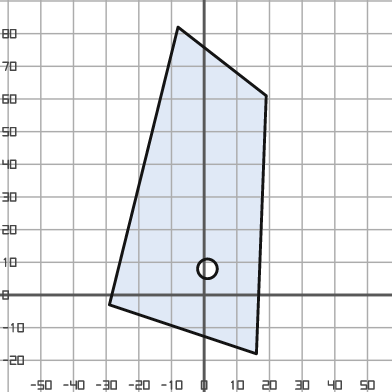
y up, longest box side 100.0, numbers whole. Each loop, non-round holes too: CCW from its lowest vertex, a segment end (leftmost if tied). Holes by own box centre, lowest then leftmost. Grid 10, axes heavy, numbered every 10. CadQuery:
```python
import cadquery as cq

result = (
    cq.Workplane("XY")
    .moveTo(16.0, -18.0)
    .lineTo(19.0, 61.0)
    .lineTo(-8.0, 82.0)
    .lineTo(-29.0, -3.0)
    .close()
    .moveTo(1.0, 8.0)
    .circle(3.0)
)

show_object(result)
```